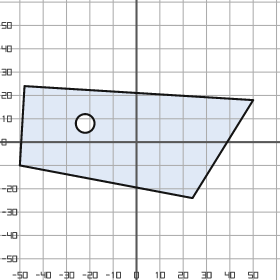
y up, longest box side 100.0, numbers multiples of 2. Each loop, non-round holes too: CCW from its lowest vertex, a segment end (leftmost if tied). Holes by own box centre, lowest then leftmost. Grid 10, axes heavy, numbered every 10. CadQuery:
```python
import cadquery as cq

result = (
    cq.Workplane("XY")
    .moveTo(24.0, -24.0)
    .lineTo(50.0, 18.0)
    .lineTo(-48.0, 24.0)
    .lineTo(-50.0, -10.0)
    .close()
    .moveTo(-22.0, 8.0)
    .circle(4.0)
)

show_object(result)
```